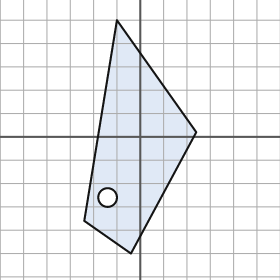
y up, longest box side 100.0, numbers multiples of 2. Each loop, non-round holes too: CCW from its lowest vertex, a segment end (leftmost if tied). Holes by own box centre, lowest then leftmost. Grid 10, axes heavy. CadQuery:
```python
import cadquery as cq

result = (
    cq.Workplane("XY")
    .moveTo(-4.0, -50.0)
    .lineTo(24.0, 2.0)
    .lineTo(-10.0, 50.0)
    .lineTo(-24.0, -36.0)
    .close()
    .moveTo(-14.0, -26.0)
    .circle(4.0)
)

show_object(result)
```